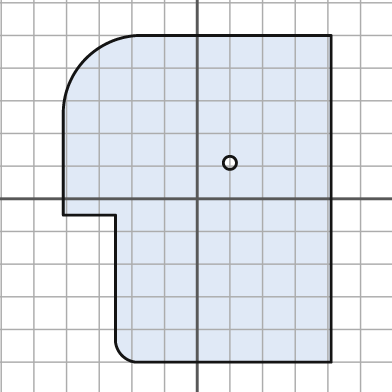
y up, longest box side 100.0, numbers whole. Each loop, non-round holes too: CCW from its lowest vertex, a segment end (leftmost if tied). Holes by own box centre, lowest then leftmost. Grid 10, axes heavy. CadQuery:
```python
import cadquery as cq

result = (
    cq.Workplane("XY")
    .moveTo(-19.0, -50.0)
    .lineTo(41.0, -50.0)
    .lineTo(41.0, 50.0)
    .lineTo(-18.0, 50.0)
    .threePointArc((-34.0, 43.0), (-41.0, 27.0))
    .lineTo(-41.0, -5.0)
    .lineTo(-25.0, -5.0)
    .lineTo(-25.0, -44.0)
    .threePointArc((-23.0, -48.0), (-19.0, -50.0))
    .close()
    .moveTo(10.0, 11.0)
    .circle(2.0)
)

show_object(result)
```